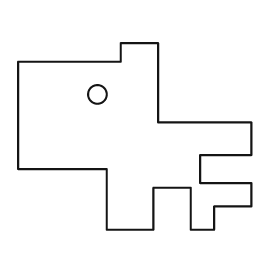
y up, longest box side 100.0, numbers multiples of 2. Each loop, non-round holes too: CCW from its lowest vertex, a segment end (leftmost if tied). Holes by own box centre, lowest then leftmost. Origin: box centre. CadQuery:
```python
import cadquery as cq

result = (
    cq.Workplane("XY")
    .moveTo(-12.0, -40.0)
    .lineTo(8.0, -40.0)
    .lineTo(8.0, -22.0)
    .lineTo(24.0, -22.0)
    .lineTo(24.0, -40.0)
    .lineTo(34.0, -40.0)
    .lineTo(34.0, -30.0)
    .lineTo(50.0, -30.0)
    .lineTo(50.0, -20.0)
    .lineTo(28.0, -20.0)
    .lineTo(28.0, -8.0)
    .lineTo(50.0, -8.0)
    .lineTo(50.0, 6.0)
    .lineTo(10.0, 6.0)
    .lineTo(10.0, 40.0)
    .lineTo(-6.0, 40.0)
    .lineTo(-6.0, 32.0)
    .lineTo(-50.0, 32.0)
    .lineTo(-50.0, -14.0)
    .lineTo(-12.0, -14.0)
    .close()
    .moveTo(-16.0, 18.0)
    .circle(4.0)
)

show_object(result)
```